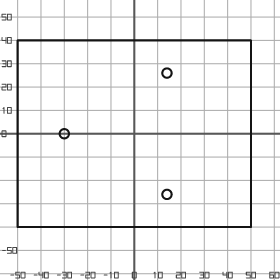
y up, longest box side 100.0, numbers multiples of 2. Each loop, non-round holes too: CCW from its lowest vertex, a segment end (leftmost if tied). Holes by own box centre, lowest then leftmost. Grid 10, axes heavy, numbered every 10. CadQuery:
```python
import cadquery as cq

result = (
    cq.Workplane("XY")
    .moveTo(-50.0, -40.0)
    .lineTo(50.0, -40.0)
    .lineTo(50.0, 40.0)
    .lineTo(-50.0, 40.0)
    .close()
    .moveTo(14.0, -26.0)
    .circle(2.0)
    .moveTo(-30.0, 0.0)
    .circle(2.0)
    .moveTo(14.0, 26.0)
    .circle(2.0)
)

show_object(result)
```